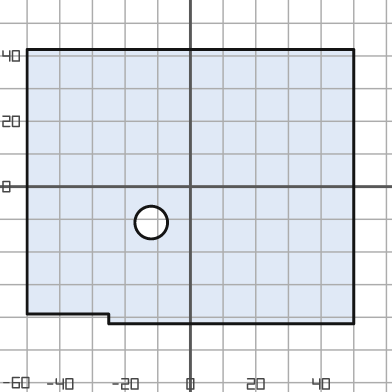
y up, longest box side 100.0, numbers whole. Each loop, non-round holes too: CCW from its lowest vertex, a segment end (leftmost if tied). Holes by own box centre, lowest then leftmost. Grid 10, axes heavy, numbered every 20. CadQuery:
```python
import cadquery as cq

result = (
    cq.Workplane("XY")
    .moveTo(-25.0, -42.0)
    .lineTo(50.0, -42.0)
    .lineTo(50.0, 42.0)
    .lineTo(-50.0, 42.0)
    .lineTo(-50.0, -39.0)
    .lineTo(-25.0, -39.0)
    .close()
    .moveTo(-12.0, -11.0)
    .circle(5.0)
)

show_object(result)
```